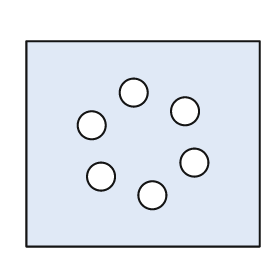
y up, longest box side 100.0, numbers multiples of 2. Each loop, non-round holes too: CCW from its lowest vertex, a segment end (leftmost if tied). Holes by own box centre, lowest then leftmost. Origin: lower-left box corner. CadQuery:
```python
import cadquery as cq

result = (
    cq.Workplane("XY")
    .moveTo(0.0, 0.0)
    .lineTo(100.0, 0.0)
    .lineTo(100.0, 88.0)
    .lineTo(0.0, 88.0)
    .close()
    .moveTo(54.0, 22.0)
    .circle(6.0)
    .moveTo(32.0, 30.0)
    .circle(6.0)
    .moveTo(72.0, 36.0)
    .circle(6.0)
    .moveTo(28.0, 52.0)
    .circle(6.0)
    .moveTo(68.0, 58.0)
    .circle(6.0)
    .moveTo(46.0, 66.0)
    .circle(6.0)
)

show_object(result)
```